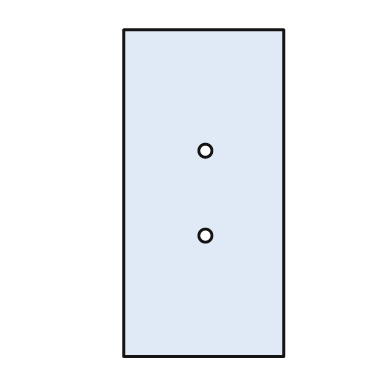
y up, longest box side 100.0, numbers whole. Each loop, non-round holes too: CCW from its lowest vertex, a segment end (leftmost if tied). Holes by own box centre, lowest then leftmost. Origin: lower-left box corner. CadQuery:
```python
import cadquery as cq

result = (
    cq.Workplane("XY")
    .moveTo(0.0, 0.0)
    .lineTo(49.0, 0.0)
    .lineTo(49.0, 100.0)
    .lineTo(0.0, 100.0)
    .close()
    .moveTo(25.0, 37.0)
    .circle(2.0)
    .moveTo(25.0, 63.0)
    .circle(2.0)
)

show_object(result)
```